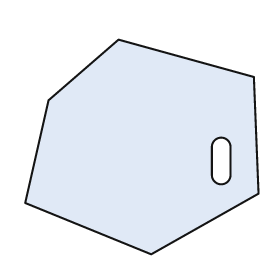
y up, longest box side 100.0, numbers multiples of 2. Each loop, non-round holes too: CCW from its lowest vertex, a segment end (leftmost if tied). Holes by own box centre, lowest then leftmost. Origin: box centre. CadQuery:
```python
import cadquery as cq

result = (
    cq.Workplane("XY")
    .moveTo(4.0, -46.0)
    .lineTo(50.0, -20.0)
    .lineTo(48.0, 30.0)
    .lineTo(-10.0, 46.0)
    .lineTo(-40.0, 20.0)
    .lineTo(-50.0, -24.0)
    .close()
    .moveTo(30.0, -12.0)
    .threePointArc((34.0, -16.0), (38.0, -12.0))
    .lineTo(38.0, 0.0)
    .threePointArc((34.0, 4.0), (30.0, 0.0))
    .close()
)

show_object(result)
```